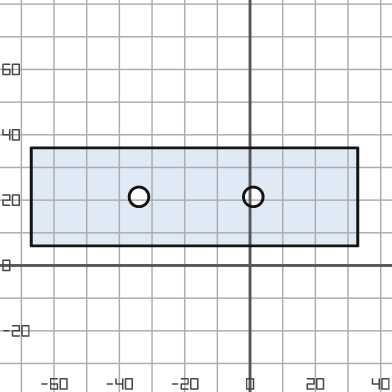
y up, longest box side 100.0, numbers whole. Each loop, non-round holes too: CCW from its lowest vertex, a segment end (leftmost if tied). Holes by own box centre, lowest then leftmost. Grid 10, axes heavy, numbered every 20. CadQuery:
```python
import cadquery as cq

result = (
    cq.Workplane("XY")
    .moveTo(-67.0, 6.0)
    .lineTo(33.0, 6.0)
    .lineTo(33.0, 36.0)
    .lineTo(-67.0, 36.0)
    .close()
    .moveTo(-34.0, 21.0)
    .circle(3.0)
    .moveTo(1.0, 21.0)
    .circle(3.0)
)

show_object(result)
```